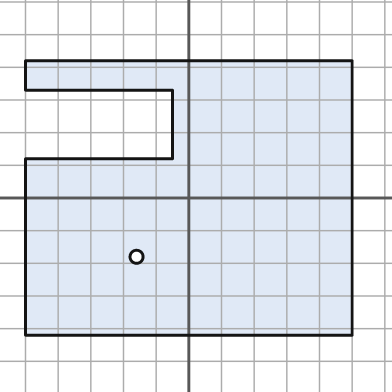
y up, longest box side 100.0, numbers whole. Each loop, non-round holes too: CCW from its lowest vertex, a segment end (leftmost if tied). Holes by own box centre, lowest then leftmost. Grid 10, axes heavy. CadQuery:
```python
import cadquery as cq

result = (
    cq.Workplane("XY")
    .moveTo(-50.0, -42.0)
    .lineTo(50.0, -42.0)
    .lineTo(50.0, 42.0)
    .lineTo(-50.0, 42.0)
    .lineTo(-50.0, 33.0)
    .lineTo(-5.0, 33.0)
    .lineTo(-5.0, 12.0)
    .lineTo(-50.0, 12.0)
    .close()
    .moveTo(-16.0, -18.0)
    .circle(2.0)
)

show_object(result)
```